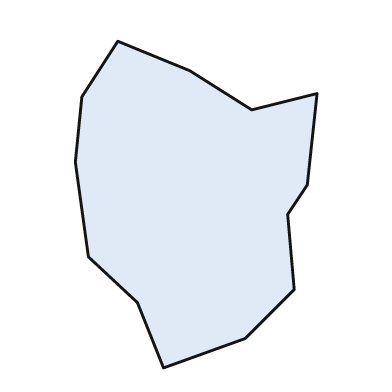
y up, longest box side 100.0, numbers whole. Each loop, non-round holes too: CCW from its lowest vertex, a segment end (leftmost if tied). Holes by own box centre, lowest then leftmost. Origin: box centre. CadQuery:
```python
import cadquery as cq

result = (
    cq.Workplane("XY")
    .moveTo(-10.0, -50.0)
    .lineTo(15.0, -41.0)
    .lineTo(30.0, -26.0)
    .lineTo(28.0, -3.0)
    .lineTo(34.0, 6.0)
    .lineTo(37.0, 34.0)
    .lineTo(17.0, 29.0)
    .lineTo(-2.0, 41.0)
    .lineTo(-24.0, 50.0)
    .lineTo(-35.0, 33.0)
    .lineTo(-37.0, 13.0)
    .lineTo(-33.0, -16.0)
    .lineTo(-18.0, -30.0)
    .close()
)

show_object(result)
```